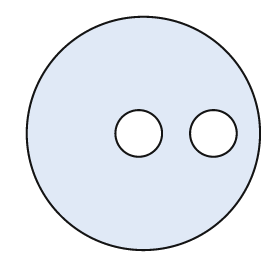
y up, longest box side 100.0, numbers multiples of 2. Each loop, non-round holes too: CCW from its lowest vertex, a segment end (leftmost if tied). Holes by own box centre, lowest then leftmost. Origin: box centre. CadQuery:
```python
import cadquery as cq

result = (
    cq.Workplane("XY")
    .moveTo(0.0, 0.0)
    .circle(50.0)
    .moveTo(-2.0, 0.0)
    .circle(10.0)
    .moveTo(30.0, 0.0)
    .circle(10.0)
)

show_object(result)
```